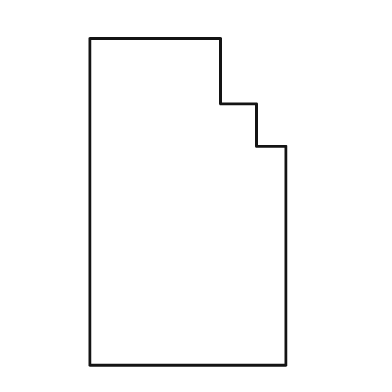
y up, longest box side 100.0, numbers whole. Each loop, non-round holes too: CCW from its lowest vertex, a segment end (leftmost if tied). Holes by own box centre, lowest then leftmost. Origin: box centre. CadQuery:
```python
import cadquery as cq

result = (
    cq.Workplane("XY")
    .moveTo(-30.0, -50.0)
    .lineTo(30.0, -50.0)
    .lineTo(30.0, 17.0)
    .lineTo(21.0, 17.0)
    .lineTo(21.0, 30.0)
    .lineTo(10.0, 30.0)
    .lineTo(10.0, 50.0)
    .lineTo(-30.0, 50.0)
    .close()
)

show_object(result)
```